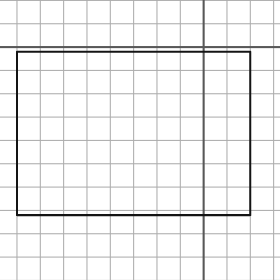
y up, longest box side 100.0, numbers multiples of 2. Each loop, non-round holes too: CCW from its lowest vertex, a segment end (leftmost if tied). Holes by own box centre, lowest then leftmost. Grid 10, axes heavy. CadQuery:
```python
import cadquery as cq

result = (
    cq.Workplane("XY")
    .moveTo(-80.0, -72.0)
    .lineTo(20.0, -72.0)
    .lineTo(20.0, -2.0)
    .lineTo(-80.0, -2.0)
    .close()
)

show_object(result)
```